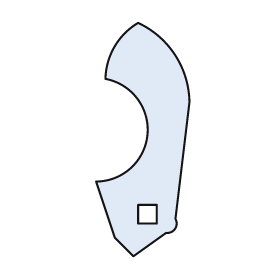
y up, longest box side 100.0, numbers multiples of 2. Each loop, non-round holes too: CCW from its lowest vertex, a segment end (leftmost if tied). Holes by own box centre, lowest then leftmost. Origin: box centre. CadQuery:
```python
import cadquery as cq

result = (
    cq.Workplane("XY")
    .moveTo(-4.0, -50.0)
    .lineTo(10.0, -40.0)
    .threePointArc((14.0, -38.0), (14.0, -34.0))
    .lineTo(20.0, 16.0)
    .threePointArc((14.0, 36.0), (-2.0, 50.0))
    .threePointArc((-12.0, 40.0), (-16.0, 26.0))
    .threePointArc((2.0, 2.0), (-20.0, -18.0))
    .lineTo(-12.0, -42.0)
    .close()
    .moveTo(-2.0, -36.0)
    .lineTo(6.0, -36.0)
    .lineTo(6.0, -28.0)
    .lineTo(-2.0, -28.0)
    .close()
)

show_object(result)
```